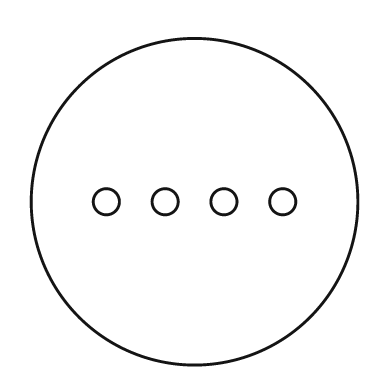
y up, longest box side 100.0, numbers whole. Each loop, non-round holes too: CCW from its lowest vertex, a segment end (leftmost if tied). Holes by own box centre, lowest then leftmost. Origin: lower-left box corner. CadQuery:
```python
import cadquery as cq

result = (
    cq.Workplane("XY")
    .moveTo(50.0, 50.0)
    .circle(50.0)
    .moveTo(23.0, 50.0)
    .circle(4.0)
    .moveTo(41.0, 50.0)
    .circle(4.0)
    .moveTo(59.0, 50.0)
    .circle(4.0)
    .moveTo(77.0, 50.0)
    .circle(4.0)
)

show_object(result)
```